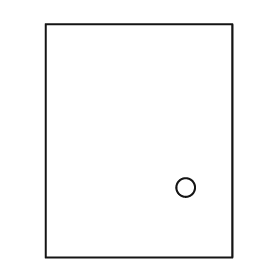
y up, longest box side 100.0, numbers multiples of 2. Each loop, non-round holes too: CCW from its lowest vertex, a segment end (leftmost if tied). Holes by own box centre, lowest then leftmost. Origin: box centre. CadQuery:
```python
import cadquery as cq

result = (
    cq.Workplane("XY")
    .moveTo(-40.0, -50.0)
    .lineTo(40.0, -50.0)
    .lineTo(40.0, 50.0)
    .lineTo(-40.0, 50.0)
    .close()
    .moveTo(20.0, -20.0)
    .circle(4.0)
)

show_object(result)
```